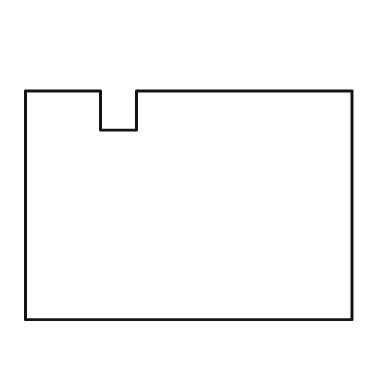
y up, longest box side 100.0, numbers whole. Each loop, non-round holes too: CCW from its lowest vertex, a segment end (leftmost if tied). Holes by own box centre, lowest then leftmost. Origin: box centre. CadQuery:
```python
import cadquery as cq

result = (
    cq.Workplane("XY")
    .moveTo(-50.0, -35.0)
    .lineTo(50.0, -35.0)
    .lineTo(50.0, 35.0)
    .lineTo(-16.0, 35.0)
    .lineTo(-16.0, 23.0)
    .lineTo(-27.0, 23.0)
    .lineTo(-27.0, 35.0)
    .lineTo(-50.0, 35.0)
    .close()
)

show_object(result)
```